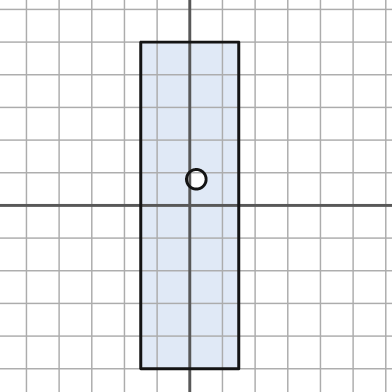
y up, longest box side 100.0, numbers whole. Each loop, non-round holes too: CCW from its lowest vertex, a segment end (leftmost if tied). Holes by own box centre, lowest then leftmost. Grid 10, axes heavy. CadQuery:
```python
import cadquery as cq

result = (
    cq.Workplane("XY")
    .moveTo(-15.0, -50.0)
    .lineTo(15.0, -50.0)
    .lineTo(15.0, 50.0)
    .lineTo(-15.0, 50.0)
    .close()
    .moveTo(2.0, 8.0)
    .circle(3.0)
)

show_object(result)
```